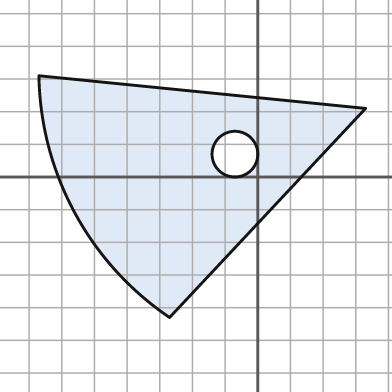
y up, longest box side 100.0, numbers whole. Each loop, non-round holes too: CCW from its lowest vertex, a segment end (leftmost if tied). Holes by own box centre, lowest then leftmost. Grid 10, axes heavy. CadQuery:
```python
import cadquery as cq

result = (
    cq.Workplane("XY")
    .moveTo(-27.0, -43.0)
    .lineTo(33.0, 21.0)
    .lineTo(-67.0, 31.0)
    .threePointArc((-56.0, -11.0), (-27.0, -43.0))
    .close()
    .moveTo(-7.0, 7.0)
    .circle(7.0)
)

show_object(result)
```